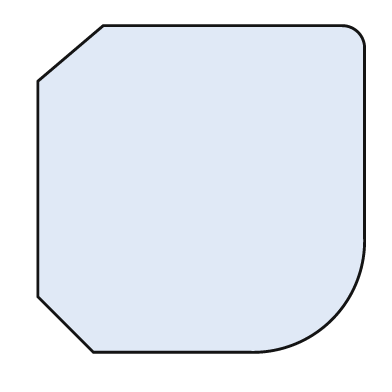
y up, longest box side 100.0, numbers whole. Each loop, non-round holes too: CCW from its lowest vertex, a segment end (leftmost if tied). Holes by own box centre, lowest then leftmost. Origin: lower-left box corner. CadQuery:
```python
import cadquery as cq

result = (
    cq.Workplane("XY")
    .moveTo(17.0, 0.0)
    .lineTo(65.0, 0.0)
    .threePointArc((90.0, 10.0), (100.0, 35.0))
    .lineTo(100.0, 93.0)
    .threePointArc((98.0, 98.0), (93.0, 100.0))
    .lineTo(20.0, 100.0)
    .lineTo(0.0, 83.0)
    .lineTo(0.0, 17.0)
    .close()
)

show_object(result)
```